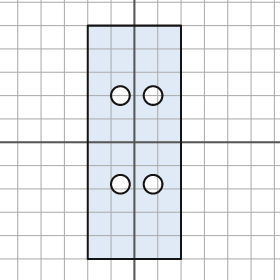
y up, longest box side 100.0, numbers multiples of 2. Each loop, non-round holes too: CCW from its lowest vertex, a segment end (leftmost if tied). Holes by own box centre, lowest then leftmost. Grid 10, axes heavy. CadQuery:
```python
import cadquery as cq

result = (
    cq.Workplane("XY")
    .moveTo(-20.0, -50.0)
    .lineTo(20.0, -50.0)
    .lineTo(20.0, 50.0)
    .lineTo(-20.0, 50.0)
    .close()
    .moveTo(-6.0, -18.0)
    .circle(4.0)
    .moveTo(8.0, -18.0)
    .circle(4.0)
    .moveTo(-6.0, 20.0)
    .circle(4.0)
    .moveTo(8.0, 20.0)
    .circle(4.0)
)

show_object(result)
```